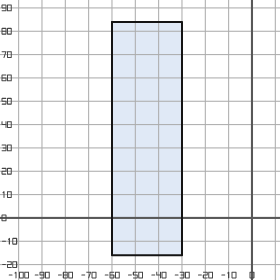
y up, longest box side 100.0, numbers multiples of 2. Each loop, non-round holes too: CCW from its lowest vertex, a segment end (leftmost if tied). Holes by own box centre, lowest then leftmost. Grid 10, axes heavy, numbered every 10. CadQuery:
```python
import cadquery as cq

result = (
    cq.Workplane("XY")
    .moveTo(-60.0, -16.0)
    .lineTo(-30.0, -16.0)
    .lineTo(-30.0, 84.0)
    .lineTo(-60.0, 84.0)
    .close()
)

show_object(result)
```